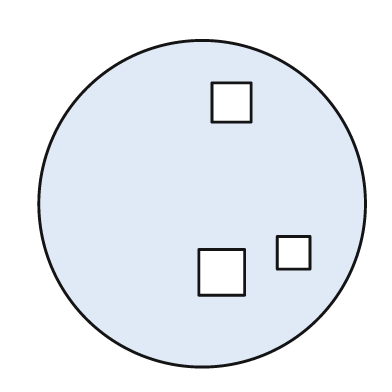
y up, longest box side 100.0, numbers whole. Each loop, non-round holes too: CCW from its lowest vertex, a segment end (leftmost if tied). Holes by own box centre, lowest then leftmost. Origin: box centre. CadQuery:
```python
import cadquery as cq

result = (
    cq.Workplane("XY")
    .moveTo(0.0, 0.0)
    .circle(50.0)
    .moveTo(-1.0, -28.0)
    .lineTo(13.0, -28.0)
    .lineTo(13.0, -14.0)
    .lineTo(-1.0, -14.0)
    .close()
    .moveTo(23.0, -20.0)
    .lineTo(33.0, -20.0)
    .lineTo(33.0, -10.0)
    .lineTo(23.0, -10.0)
    .close()
    .moveTo(3.0, 25.0)
    .lineTo(15.0, 25.0)
    .lineTo(15.0, 37.0)
    .lineTo(3.0, 37.0)
    .close()
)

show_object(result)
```